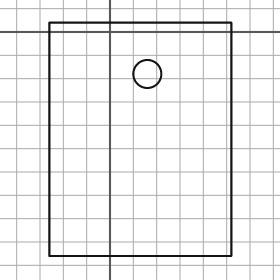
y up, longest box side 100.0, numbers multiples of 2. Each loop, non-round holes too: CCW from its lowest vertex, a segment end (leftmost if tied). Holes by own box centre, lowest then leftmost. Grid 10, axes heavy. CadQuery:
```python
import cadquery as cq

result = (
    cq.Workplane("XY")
    .moveTo(-26.0, -96.0)
    .lineTo(52.0, -96.0)
    .lineTo(52.0, 4.0)
    .lineTo(-26.0, 4.0)
    .close()
    .moveTo(16.0, -18.0)
    .circle(6.0)
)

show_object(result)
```